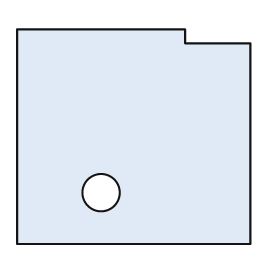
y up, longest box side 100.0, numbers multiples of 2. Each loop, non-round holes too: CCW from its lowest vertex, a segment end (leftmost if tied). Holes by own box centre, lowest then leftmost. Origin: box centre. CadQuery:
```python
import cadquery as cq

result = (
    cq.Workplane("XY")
    .moveTo(-50.0, -46.0)
    .lineTo(50.0, -46.0)
    .lineTo(50.0, 40.0)
    .lineTo(22.0, 40.0)
    .lineTo(22.0, 46.0)
    .lineTo(-50.0, 46.0)
    .close()
    .moveTo(-14.0, -24.0)
    .circle(8.0)
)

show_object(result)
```